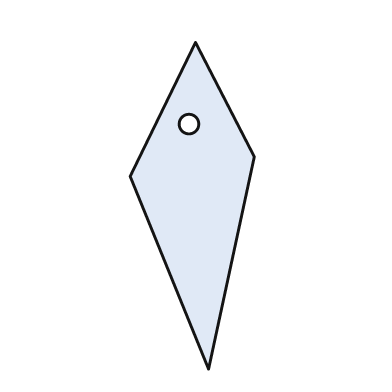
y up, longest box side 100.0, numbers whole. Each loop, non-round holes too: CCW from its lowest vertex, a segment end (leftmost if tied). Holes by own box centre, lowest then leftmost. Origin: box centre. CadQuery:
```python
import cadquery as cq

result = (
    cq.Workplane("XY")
    .moveTo(5.0, -50.0)
    .lineTo(19.0, 15.0)
    .lineTo(1.0, 50.0)
    .lineTo(-19.0, 9.0)
    .close()
    .moveTo(-1.0, 25.0)
    .circle(3.0)
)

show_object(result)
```